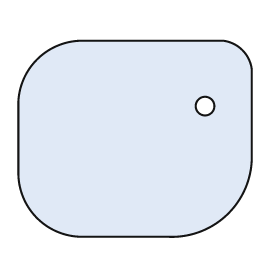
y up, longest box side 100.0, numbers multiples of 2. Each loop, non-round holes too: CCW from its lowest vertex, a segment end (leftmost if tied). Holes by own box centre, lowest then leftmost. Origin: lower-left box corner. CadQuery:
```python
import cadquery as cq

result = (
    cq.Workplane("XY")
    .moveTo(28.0, 0.0)
    .lineTo(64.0, 0.0)
    .threePointArc((90.0, 10.0), (100.0, 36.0))
    .lineTo(100.0, 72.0)
    .threePointArc((96.0, 80.0), (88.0, 84.0))
    .lineTo(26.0, 84.0)
    .threePointArc((8.0, 76.0), (0.0, 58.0))
    .lineTo(0.0, 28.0)
    .threePointArc((8.0, 8.0), (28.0, 0.0))
    .close()
    .moveTo(80.0, 56.0)
    .circle(4.0)
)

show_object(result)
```